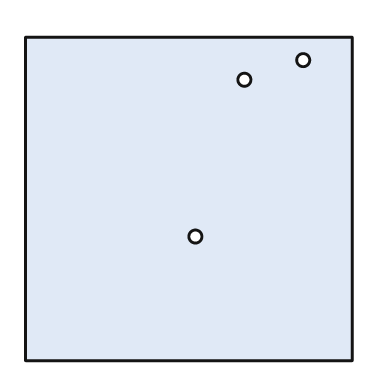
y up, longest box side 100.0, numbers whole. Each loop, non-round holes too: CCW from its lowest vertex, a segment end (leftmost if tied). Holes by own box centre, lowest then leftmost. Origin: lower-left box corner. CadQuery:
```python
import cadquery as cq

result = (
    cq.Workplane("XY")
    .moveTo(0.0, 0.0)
    .lineTo(100.0, 0.0)
    .lineTo(100.0, 99.0)
    .lineTo(0.0, 99.0)
    .close()
    .moveTo(52.0, 38.0)
    .circle(2.0)
    .moveTo(67.0, 86.0)
    .circle(2.0)
    .moveTo(85.0, 92.0)
    .circle(2.0)
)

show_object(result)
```